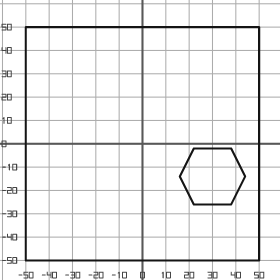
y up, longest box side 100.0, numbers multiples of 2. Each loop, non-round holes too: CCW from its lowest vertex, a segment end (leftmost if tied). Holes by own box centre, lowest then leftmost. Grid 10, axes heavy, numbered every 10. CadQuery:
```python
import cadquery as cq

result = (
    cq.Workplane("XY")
    .moveTo(-50.0, -50.0)
    .lineTo(50.0, -50.0)
    .lineTo(50.0, 50.0)
    .lineTo(-50.0, 50.0)
    .close()
    .moveTo(22.0, -26.0)
    .lineTo(38.0, -26.0)
    .lineTo(44.0, -14.0)
    .lineTo(38.0, -2.0)
    .lineTo(22.0, -2.0)
    .lineTo(16.0, -14.0)
    .close()
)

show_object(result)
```